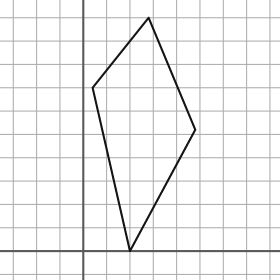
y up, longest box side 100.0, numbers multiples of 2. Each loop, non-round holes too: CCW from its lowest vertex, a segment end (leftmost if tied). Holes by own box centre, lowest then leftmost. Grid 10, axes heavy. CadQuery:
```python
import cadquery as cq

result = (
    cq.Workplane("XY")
    .moveTo(20.0, 0.0)
    .lineTo(48.0, 52.0)
    .lineTo(28.0, 100.0)
    .lineTo(4.0, 70.0)
    .close()
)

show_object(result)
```